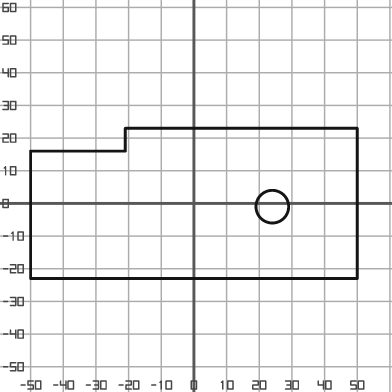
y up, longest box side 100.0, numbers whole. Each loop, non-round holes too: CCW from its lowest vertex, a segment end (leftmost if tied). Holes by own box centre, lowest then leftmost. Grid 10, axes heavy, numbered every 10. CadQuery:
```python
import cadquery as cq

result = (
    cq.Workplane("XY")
    .moveTo(-50.0, -23.0)
    .lineTo(50.0, -23.0)
    .lineTo(50.0, 23.0)
    .lineTo(-21.0, 23.0)
    .lineTo(-21.0, 16.0)
    .lineTo(-50.0, 16.0)
    .close()
    .moveTo(24.0, -1.0)
    .circle(5.0)
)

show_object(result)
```